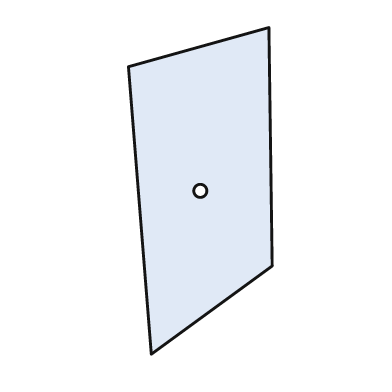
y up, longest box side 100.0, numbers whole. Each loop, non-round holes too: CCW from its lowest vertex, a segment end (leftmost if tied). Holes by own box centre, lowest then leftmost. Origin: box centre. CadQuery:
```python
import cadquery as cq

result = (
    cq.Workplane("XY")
    .moveTo(-15.0, -50.0)
    .lineTo(22.0, -23.0)
    .lineTo(21.0, 50.0)
    .lineTo(-22.0, 38.0)
    .close()
    .moveTo(0.0, 0.0)
    .circle(2.0)
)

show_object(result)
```